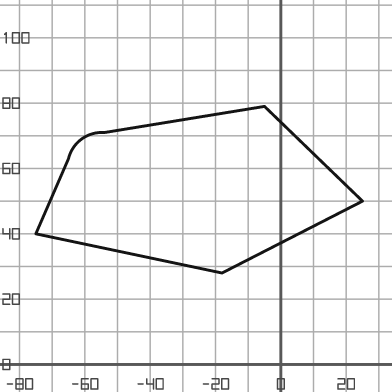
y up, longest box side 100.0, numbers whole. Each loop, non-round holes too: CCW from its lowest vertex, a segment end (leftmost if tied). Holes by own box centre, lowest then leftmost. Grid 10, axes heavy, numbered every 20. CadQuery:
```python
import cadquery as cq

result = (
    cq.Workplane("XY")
    .moveTo(-18.0, 28.0)
    .lineTo(25.0, 50.0)
    .lineTo(-5.0, 79.0)
    .lineTo(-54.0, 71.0)
    .threePointArc((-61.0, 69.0), (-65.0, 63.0))
    .lineTo(-75.0, 40.0)
    .close()
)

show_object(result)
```